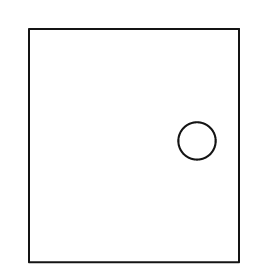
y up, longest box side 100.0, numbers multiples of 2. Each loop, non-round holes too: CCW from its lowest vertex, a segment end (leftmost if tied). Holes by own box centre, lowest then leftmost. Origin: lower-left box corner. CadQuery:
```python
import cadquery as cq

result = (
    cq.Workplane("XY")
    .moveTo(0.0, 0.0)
    .lineTo(90.0, 0.0)
    .lineTo(90.0, 100.0)
    .lineTo(0.0, 100.0)
    .close()
    .moveTo(72.0, 52.0)
    .circle(8.0)
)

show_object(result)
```